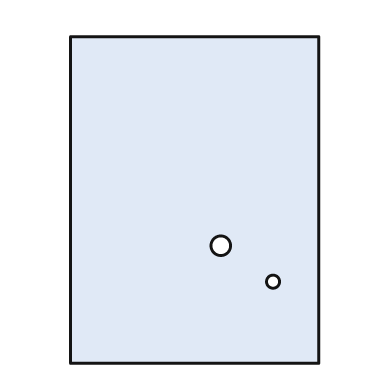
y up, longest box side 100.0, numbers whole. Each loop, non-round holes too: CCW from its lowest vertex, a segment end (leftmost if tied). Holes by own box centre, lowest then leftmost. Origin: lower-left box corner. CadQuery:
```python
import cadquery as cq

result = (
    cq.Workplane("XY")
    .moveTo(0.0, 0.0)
    .lineTo(76.0, 0.0)
    .lineTo(76.0, 100.0)
    .lineTo(0.0, 100.0)
    .close()
    .moveTo(62.0, 25.0)
    .circle(2.0)
    .moveTo(46.0, 36.0)
    .circle(3.0)
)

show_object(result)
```